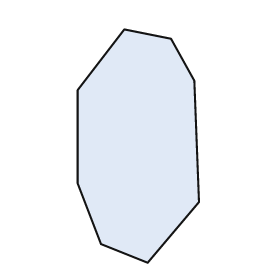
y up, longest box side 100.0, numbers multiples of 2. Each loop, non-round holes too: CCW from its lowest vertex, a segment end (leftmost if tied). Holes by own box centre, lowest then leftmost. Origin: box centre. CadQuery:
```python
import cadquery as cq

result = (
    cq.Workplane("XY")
    .moveTo(4.0, -50.0)
    .lineTo(26.0, -24.0)
    .lineTo(24.0, 28.0)
    .lineTo(14.0, 46.0)
    .lineTo(-6.0, 50.0)
    .lineTo(-26.0, 24.0)
    .lineTo(-26.0, -16.0)
    .lineTo(-16.0, -42.0)
    .close()
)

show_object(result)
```